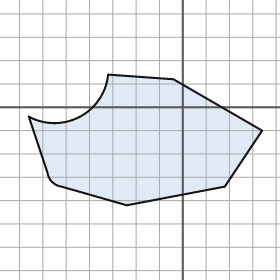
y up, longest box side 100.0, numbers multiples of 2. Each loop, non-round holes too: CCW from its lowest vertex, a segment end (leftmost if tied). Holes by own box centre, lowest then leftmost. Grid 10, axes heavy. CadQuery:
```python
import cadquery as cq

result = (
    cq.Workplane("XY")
    .moveTo(-24.0, -42.0)
    .lineTo(18.0, -34.0)
    .lineTo(34.0, -10.0)
    .lineTo(-4.0, 12.0)
    .lineTo(-32.0, 14.0)
    .threePointArc((-44.0, -4.0), (-66.0, -4.0))
    .lineTo(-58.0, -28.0)
    .threePointArc((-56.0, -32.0), (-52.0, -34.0))
    .close()
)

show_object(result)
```